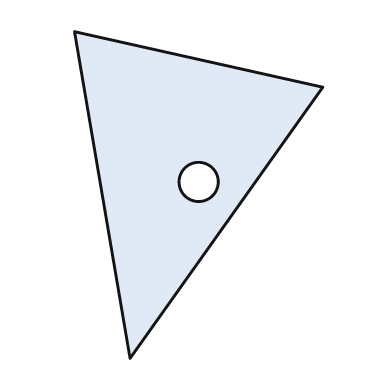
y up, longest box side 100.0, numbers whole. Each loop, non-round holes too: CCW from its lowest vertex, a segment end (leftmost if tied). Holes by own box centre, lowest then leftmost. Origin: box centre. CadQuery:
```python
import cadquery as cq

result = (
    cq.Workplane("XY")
    .moveTo(-21.0, -50.0)
    .lineTo(38.0, 33.0)
    .lineTo(-38.0, 50.0)
    .close()
    .moveTo(0.0, 4.0)
    .circle(6.0)
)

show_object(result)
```